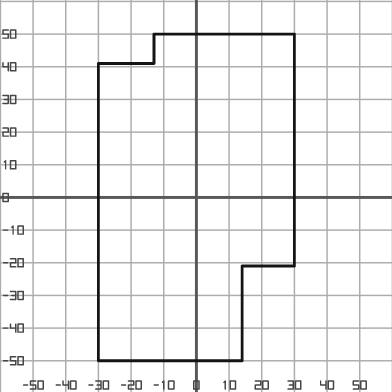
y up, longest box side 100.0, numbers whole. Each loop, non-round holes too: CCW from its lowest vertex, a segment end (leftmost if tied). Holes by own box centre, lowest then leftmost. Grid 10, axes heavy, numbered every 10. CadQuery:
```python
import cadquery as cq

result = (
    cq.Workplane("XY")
    .moveTo(-30.0, -50.0)
    .lineTo(14.0, -50.0)
    .lineTo(14.0, -21.0)
    .lineTo(30.0, -21.0)
    .lineTo(30.0, 50.0)
    .lineTo(-13.0, 50.0)
    .lineTo(-13.0, 41.0)
    .lineTo(-30.0, 41.0)
    .close()
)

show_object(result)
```